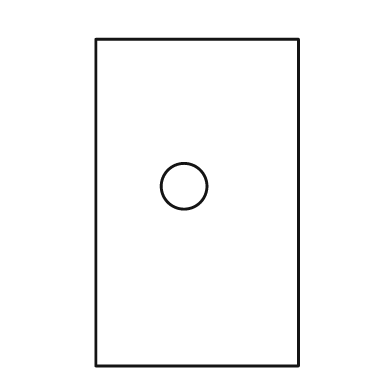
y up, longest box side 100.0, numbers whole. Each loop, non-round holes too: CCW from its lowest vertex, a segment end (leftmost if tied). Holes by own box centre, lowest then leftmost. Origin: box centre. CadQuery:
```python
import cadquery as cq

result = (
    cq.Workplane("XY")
    .moveTo(-31.0, -50.0)
    .lineTo(31.0, -50.0)
    .lineTo(31.0, 50.0)
    .lineTo(-31.0, 50.0)
    .close()
    .moveTo(-4.0, 5.0)
    .circle(7.0)
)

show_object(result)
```